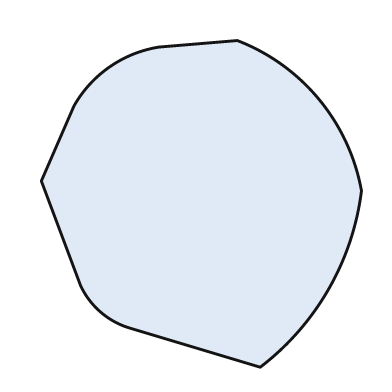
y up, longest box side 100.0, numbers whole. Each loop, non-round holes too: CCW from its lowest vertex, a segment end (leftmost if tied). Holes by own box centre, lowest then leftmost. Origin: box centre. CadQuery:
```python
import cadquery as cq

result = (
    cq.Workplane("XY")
    .moveTo(18.0, -50.0)
    .threePointArc((39.0, -26.0), (49.0, 4.0))
    .threePointArc((36.0, 32.0), (11.0, 50.0))
    .lineTo(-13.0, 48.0)
    .threePointArc((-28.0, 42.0), (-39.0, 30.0))
    .lineTo(-49.0, 7.0)
    .lineTo(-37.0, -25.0)
    .threePointArc((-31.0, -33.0), (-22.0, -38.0))
    .close()
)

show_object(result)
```